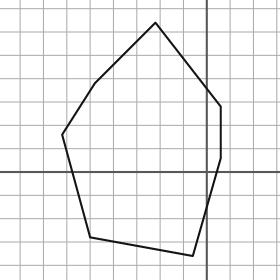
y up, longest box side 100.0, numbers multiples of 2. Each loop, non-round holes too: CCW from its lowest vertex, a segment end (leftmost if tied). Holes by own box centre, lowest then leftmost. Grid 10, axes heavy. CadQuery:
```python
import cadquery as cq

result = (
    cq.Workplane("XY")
    .moveTo(-6.0, -36.0)
    .lineTo(6.0, 6.0)
    .lineTo(6.0, 28.0)
    .lineTo(-22.0, 64.0)
    .lineTo(-48.0, 38.0)
    .lineTo(-62.0, 16.0)
    .lineTo(-50.0, -28.0)
    .close()
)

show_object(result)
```